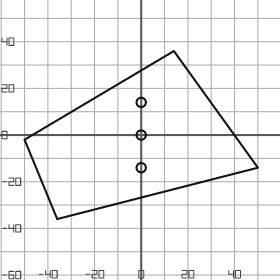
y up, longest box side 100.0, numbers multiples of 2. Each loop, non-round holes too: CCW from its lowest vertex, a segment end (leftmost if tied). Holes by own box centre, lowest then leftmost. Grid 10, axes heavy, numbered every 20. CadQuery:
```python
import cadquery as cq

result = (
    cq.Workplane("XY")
    .moveTo(-36.0, -36.0)
    .lineTo(50.0, -14.0)
    .lineTo(14.0, 36.0)
    .lineTo(-50.0, -2.0)
    .close()
    .moveTo(0.0, -14.0)
    .circle(2.0)
    .moveTo(0.0, 0.0)
    .circle(2.0)
    .moveTo(0.0, 14.0)
    .circle(2.0)
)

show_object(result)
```